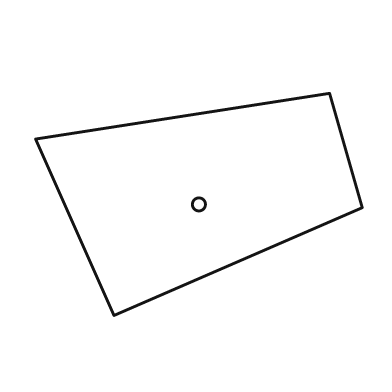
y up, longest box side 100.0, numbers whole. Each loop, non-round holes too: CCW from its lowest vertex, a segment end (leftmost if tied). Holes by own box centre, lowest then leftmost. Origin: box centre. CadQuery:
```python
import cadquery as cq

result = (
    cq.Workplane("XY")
    .moveTo(-26.0, -34.0)
    .lineTo(50.0, -1.0)
    .lineTo(40.0, 34.0)
    .lineTo(-50.0, 20.0)
    .close()
    .moveTo(0.0, 0.0)
    .circle(2.0)
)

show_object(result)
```